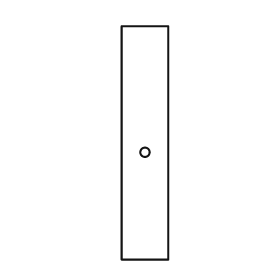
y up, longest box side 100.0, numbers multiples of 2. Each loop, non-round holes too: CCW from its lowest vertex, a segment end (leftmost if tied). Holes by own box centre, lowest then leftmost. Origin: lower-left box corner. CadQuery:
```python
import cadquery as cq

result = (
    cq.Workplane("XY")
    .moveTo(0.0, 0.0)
    .lineTo(20.0, 0.0)
    .lineTo(20.0, 100.0)
    .lineTo(0.0, 100.0)
    .close()
    .moveTo(10.0, 46.0)
    .circle(2.0)
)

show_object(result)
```